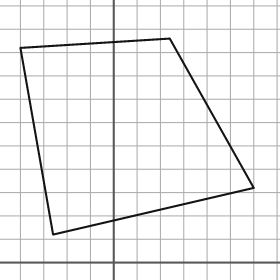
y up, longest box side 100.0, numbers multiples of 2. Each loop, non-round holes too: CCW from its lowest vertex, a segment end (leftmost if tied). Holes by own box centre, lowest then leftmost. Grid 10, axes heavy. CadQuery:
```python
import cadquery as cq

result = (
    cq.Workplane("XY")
    .moveTo(-26.0, 12.0)
    .lineTo(60.0, 32.0)
    .lineTo(24.0, 96.0)
    .lineTo(-40.0, 92.0)
    .close()
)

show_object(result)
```